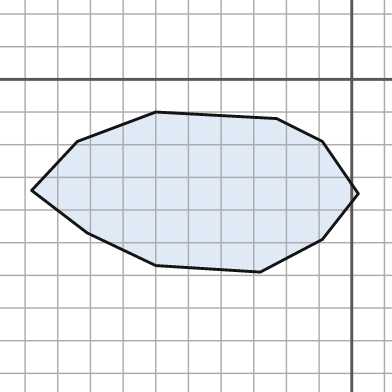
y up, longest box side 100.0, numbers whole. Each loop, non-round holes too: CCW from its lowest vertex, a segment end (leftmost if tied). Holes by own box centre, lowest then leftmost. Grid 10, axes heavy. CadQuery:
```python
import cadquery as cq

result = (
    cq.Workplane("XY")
    .moveTo(-28.0, -59.0)
    .lineTo(-9.0, -49.0)
    .lineTo(2.0, -35.0)
    .lineTo(-9.0, -19.0)
    .lineTo(-23.0, -12.0)
    .lineTo(-60.0, -10.0)
    .lineTo(-84.0, -19.0)
    .lineTo(-98.0, -34.0)
    .lineTo(-81.0, -47.0)
    .lineTo(-60.0, -57.0)
    .close()
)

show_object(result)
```